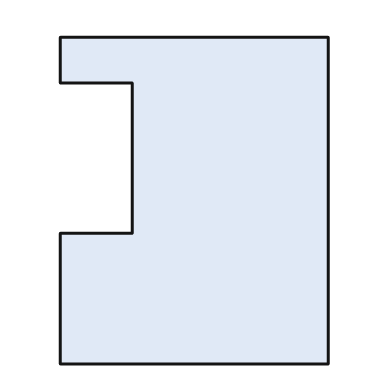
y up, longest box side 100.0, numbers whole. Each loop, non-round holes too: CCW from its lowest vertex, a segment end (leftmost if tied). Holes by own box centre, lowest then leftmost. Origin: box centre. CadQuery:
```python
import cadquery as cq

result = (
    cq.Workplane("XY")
    .moveTo(-41.0, -50.0)
    .lineTo(41.0, -50.0)
    .lineTo(41.0, 50.0)
    .lineTo(-41.0, 50.0)
    .lineTo(-41.0, 36.0)
    .lineTo(-19.0, 36.0)
    .lineTo(-19.0, -10.0)
    .lineTo(-41.0, -10.0)
    .close()
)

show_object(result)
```